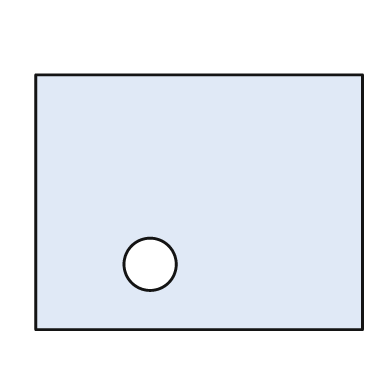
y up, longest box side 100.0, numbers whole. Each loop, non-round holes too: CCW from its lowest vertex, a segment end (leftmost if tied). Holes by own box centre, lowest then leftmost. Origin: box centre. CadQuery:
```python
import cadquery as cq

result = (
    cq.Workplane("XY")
    .moveTo(-50.0, -39.0)
    .lineTo(50.0, -39.0)
    .lineTo(50.0, 39.0)
    .lineTo(-50.0, 39.0)
    .close()
    .moveTo(-15.0, -19.0)
    .circle(8.0)
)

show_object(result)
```